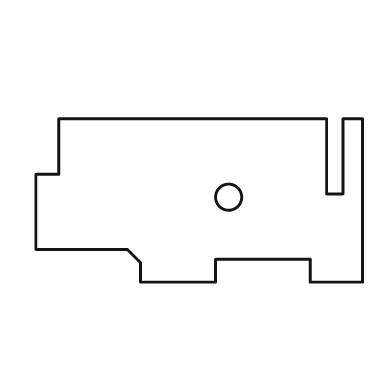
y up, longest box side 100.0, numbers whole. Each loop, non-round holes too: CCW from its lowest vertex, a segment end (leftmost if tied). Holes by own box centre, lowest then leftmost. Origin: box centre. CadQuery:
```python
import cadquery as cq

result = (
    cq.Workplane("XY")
    .moveTo(-18.0, -25.0)
    .lineTo(5.0, -25.0)
    .lineTo(5.0, -18.0)
    .lineTo(34.0, -18.0)
    .lineTo(34.0, -25.0)
    .lineTo(50.0, -25.0)
    .lineTo(50.0, 25.0)
    .lineTo(44.0, 25.0)
    .lineTo(44.0, 2.0)
    .lineTo(39.0, 2.0)
    .lineTo(39.0, 25.0)
    .lineTo(-43.0, 25.0)
    .lineTo(-43.0, 8.0)
    .lineTo(-50.0, 8.0)
    .lineTo(-50.0, -15.0)
    .lineTo(-22.0, -15.0)
    .lineTo(-18.0, -19.0)
    .close()
    .moveTo(9.0, 1.0)
    .circle(4.0)
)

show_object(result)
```